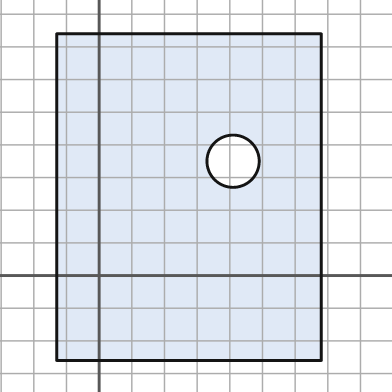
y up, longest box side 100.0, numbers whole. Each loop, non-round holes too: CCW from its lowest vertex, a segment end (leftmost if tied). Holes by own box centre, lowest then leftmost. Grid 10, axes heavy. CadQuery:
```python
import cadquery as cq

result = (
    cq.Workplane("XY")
    .moveTo(-13.0, -26.0)
    .lineTo(68.0, -26.0)
    .lineTo(68.0, 74.0)
    .lineTo(-13.0, 74.0)
    .close()
    .moveTo(41.0, 35.0)
    .circle(8.0)
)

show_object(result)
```